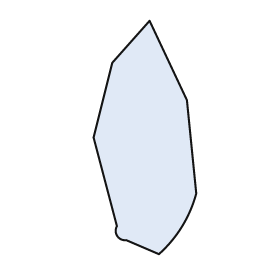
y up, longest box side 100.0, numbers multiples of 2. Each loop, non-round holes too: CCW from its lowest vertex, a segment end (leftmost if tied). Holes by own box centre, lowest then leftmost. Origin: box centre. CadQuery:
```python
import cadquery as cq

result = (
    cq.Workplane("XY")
    .moveTo(6.0, -50.0)
    .threePointArc((16.0, -38.0), (22.0, -24.0))
    .lineTo(18.0, 16.0)
    .lineTo(2.0, 50.0)
    .lineTo(-14.0, 32.0)
    .lineTo(-22.0, 0.0)
    .lineTo(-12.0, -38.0)
    .threePointArc((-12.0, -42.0), (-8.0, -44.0))
    .close()
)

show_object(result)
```